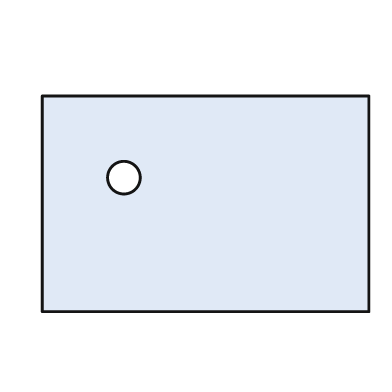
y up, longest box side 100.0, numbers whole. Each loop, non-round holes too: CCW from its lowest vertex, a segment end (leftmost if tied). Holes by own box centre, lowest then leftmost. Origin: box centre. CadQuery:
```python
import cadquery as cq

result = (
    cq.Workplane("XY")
    .moveTo(-50.0, -33.0)
    .lineTo(50.0, -33.0)
    .lineTo(50.0, 33.0)
    .lineTo(-50.0, 33.0)
    .close()
    .moveTo(-25.0, 8.0)
    .circle(5.0)
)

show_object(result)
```